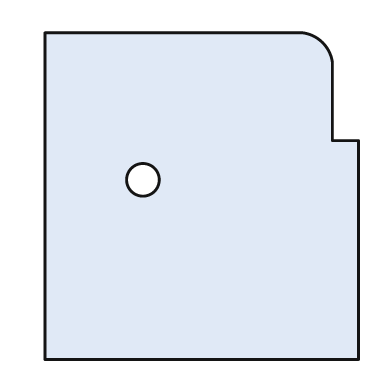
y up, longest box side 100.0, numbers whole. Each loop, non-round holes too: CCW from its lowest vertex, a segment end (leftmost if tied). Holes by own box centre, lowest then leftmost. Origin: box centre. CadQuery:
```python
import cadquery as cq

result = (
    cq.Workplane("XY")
    .moveTo(-48.0, -50.0)
    .lineTo(48.0, -50.0)
    .lineTo(48.0, 17.0)
    .lineTo(40.0, 17.0)
    .lineTo(40.0, 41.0)
    .threePointArc((37.0, 47.0), (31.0, 50.0))
    .lineTo(-48.0, 50.0)
    .close()
    .moveTo(-18.0, 5.0)
    .circle(5.0)
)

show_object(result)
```